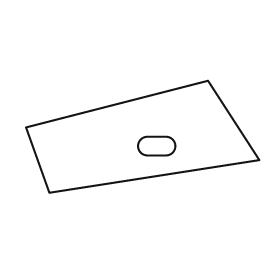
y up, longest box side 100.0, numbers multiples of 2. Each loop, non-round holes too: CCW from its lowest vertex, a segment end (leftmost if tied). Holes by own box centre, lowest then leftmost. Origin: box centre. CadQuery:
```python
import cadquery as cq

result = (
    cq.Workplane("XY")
    .moveTo(-40.0, -24.0)
    .lineTo(50.0, -10.0)
    .lineTo(28.0, 24.0)
    .lineTo(-50.0, 4.0)
    .close()
    .moveTo(2.0, -8.0)
    .lineTo(10.0, -8.0)
    .threePointArc((14.0, -4.0), (10.0, 0.0))
    .lineTo(2.0, 0.0)
    .threePointArc((-2.0, -4.0), (2.0, -8.0))
    .close()
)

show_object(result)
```